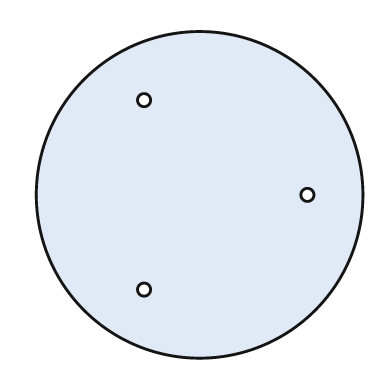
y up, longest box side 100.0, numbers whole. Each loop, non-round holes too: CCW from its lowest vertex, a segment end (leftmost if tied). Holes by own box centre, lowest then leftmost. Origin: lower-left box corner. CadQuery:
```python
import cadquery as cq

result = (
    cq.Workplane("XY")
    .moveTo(50.0, 50.0)
    .circle(50.0)
    .moveTo(33.0, 21.0)
    .circle(2.0)
    .moveTo(83.0, 50.0)
    .circle(2.0)
    .moveTo(33.0, 79.0)
    .circle(2.0)
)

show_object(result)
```